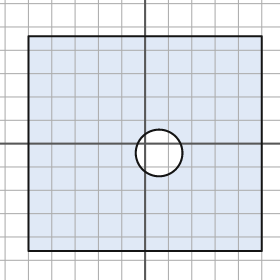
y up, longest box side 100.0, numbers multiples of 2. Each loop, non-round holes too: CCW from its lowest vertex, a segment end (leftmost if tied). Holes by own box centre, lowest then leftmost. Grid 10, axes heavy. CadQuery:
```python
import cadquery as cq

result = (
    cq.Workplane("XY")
    .moveTo(-50.0, -46.0)
    .lineTo(50.0, -46.0)
    .lineTo(50.0, 46.0)
    .lineTo(-50.0, 46.0)
    .close()
    .moveTo(6.0, -4.0)
    .circle(10.0)
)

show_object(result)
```